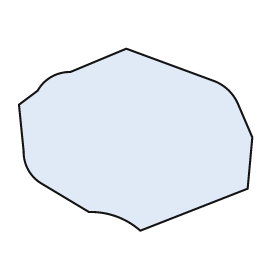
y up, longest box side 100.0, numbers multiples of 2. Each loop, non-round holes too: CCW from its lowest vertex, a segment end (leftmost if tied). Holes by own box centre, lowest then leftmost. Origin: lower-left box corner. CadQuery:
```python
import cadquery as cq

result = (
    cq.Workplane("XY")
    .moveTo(52.0, 0.0)
    .lineTo(98.0, 18.0)
    .lineTo(100.0, 40.0)
    .lineTo(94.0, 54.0)
    .threePointArc((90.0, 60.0), (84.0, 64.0))
    .lineTo(46.0, 78.0)
    .lineTo(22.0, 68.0)
    .threePointArc((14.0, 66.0), (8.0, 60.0))
    .lineTo(0.0, 54.0)
    .lineTo(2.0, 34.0)
    .threePointArc((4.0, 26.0), (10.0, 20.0))
    .lineTo(30.0, 8.0)
    .threePointArc((42.0, 6.0), (52.0, 0.0))
    .close()
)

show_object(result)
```